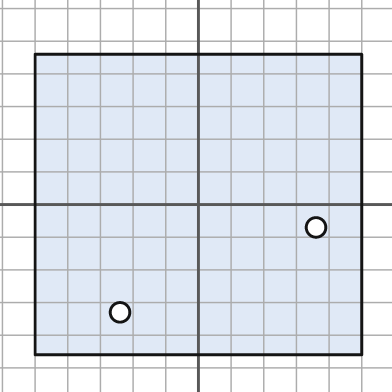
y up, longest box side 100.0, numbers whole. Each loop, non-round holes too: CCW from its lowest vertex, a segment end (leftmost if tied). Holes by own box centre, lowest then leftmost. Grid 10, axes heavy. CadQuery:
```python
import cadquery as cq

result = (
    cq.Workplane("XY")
    .moveTo(-50.0, -46.0)
    .lineTo(50.0, -46.0)
    .lineTo(50.0, 46.0)
    .lineTo(-50.0, 46.0)
    .close()
    .moveTo(-24.0, -33.0)
    .circle(3.0)
    .moveTo(36.0, -7.0)
    .circle(3.0)
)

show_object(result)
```